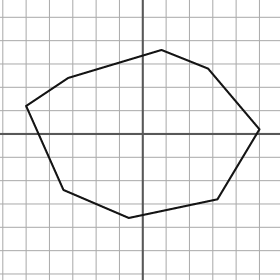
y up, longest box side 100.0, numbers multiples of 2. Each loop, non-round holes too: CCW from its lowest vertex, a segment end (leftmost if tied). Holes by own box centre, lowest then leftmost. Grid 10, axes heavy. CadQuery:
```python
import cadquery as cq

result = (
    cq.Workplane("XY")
    .moveTo(-6.0, -36.0)
    .lineTo(32.0, -28.0)
    .lineTo(50.0, 2.0)
    .lineTo(28.0, 28.0)
    .lineTo(8.0, 36.0)
    .lineTo(-32.0, 24.0)
    .lineTo(-50.0, 12.0)
    .lineTo(-34.0, -24.0)
    .close()
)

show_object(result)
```